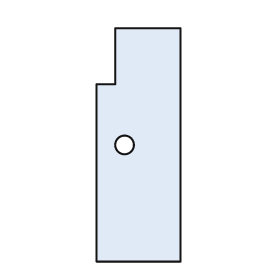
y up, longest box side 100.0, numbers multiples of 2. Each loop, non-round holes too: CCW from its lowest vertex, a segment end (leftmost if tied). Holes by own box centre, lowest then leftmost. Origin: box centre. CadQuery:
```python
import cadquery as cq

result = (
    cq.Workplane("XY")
    .moveTo(-18.0, -50.0)
    .lineTo(18.0, -50.0)
    .lineTo(18.0, 50.0)
    .lineTo(-10.0, 50.0)
    .lineTo(-10.0, 26.0)
    .lineTo(-18.0, 26.0)
    .close()
    .moveTo(-6.0, 0.0)
    .circle(4.0)
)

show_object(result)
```